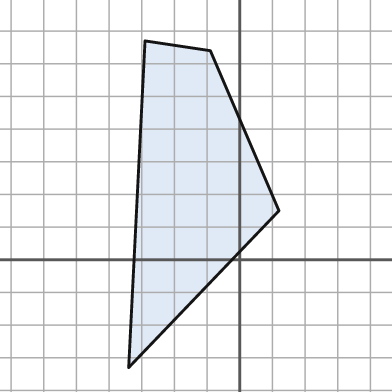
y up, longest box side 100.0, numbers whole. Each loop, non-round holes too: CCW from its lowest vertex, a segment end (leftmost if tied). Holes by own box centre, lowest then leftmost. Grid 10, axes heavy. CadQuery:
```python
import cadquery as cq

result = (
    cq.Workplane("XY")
    .moveTo(-34.0, -33.0)
    .lineTo(12.0, 15.0)
    .lineTo(-9.0, 64.0)
    .lineTo(-29.0, 67.0)
    .close()
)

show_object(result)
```